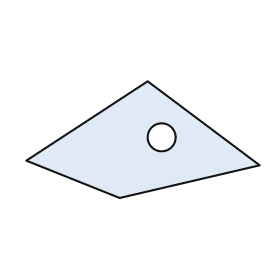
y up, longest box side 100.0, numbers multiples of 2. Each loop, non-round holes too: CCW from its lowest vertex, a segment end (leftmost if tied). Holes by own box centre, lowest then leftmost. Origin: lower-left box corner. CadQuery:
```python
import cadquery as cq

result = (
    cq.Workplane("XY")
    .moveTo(40.0, 0.0)
    .lineTo(100.0, 14.0)
    .lineTo(52.0, 50.0)
    .lineTo(0.0, 16.0)
    .close()
    .moveTo(58.0, 26.0)
    .circle(6.0)
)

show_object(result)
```